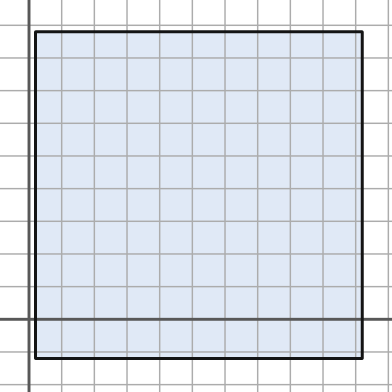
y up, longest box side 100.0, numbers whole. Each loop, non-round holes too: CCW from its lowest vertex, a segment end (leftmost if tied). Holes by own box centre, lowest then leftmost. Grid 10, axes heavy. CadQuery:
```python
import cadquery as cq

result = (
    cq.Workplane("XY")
    .moveTo(2.0, -12.0)
    .lineTo(102.0, -12.0)
    .lineTo(102.0, 88.0)
    .lineTo(2.0, 88.0)
    .close()
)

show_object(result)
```